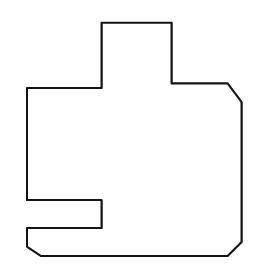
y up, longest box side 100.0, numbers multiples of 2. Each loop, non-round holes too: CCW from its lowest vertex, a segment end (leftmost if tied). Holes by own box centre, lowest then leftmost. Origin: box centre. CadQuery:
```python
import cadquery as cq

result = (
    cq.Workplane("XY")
    .moveTo(-40.0, -50.0)
    .lineTo(40.0, -50.0)
    .lineTo(46.0, -44.0)
    .lineTo(46.0, 16.0)
    .lineTo(40.0, 24.0)
    .lineTo(16.0, 24.0)
    .lineTo(16.0, 50.0)
    .lineTo(-14.0, 50.0)
    .lineTo(-14.0, 22.0)
    .lineTo(-46.0, 22.0)
    .lineTo(-46.0, -26.0)
    .lineTo(-14.0, -26.0)
    .lineTo(-14.0, -38.0)
    .lineTo(-46.0, -38.0)
    .lineTo(-46.0, -46.0)
    .close()
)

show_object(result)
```